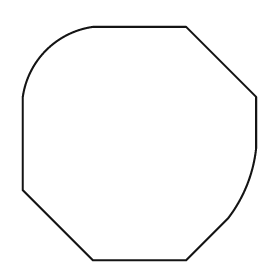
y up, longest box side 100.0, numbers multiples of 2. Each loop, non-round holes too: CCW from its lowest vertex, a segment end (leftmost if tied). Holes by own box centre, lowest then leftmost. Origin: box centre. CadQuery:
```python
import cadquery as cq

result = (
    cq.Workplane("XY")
    .moveTo(-20.0, -50.0)
    .lineTo(20.0, -50.0)
    .lineTo(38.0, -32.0)
    .threePointArc((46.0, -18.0), (50.0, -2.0))
    .lineTo(50.0, 20.0)
    .lineTo(20.0, 50.0)
    .lineTo(-20.0, 50.0)
    .threePointArc((-40.0, 40.0), (-50.0, 20.0))
    .lineTo(-50.0, -20.0)
    .close()
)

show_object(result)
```